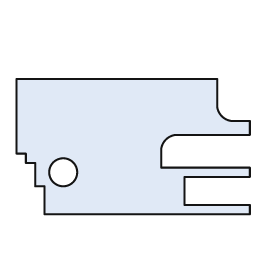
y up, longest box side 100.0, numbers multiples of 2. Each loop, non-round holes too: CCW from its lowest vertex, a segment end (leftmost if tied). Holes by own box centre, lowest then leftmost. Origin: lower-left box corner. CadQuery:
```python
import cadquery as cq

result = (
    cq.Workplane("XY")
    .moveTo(12.0, 0.0)
    .lineTo(100.0, 0.0)
    .lineTo(100.0, 4.0)
    .lineTo(72.0, 4.0)
    .lineTo(72.0, 16.0)
    .lineTo(100.0, 16.0)
    .lineTo(100.0, 20.0)
    .lineTo(62.0, 20.0)
    .lineTo(62.0, 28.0)
    .threePointArc((64.0, 32.0), (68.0, 34.0))
    .lineTo(100.0, 34.0)
    .lineTo(100.0, 40.0)
    .lineTo(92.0, 40.0)
    .threePointArc((88.0, 42.0), (86.0, 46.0))
    .lineTo(86.0, 58.0)
    .lineTo(0.0, 58.0)
    .lineTo(0.0, 26.0)
    .lineTo(4.0, 26.0)
    .lineTo(4.0, 22.0)
    .lineTo(8.0, 22.0)
    .lineTo(8.0, 12.0)
    .lineTo(12.0, 12.0)
    .close()
    .moveTo(20.0, 18.0)
    .circle(6.0)
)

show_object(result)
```